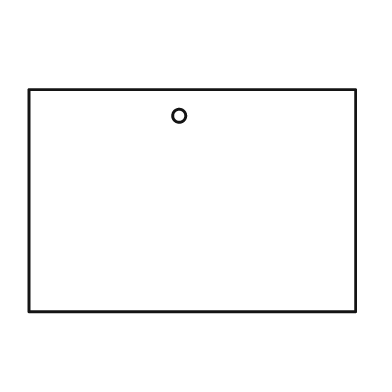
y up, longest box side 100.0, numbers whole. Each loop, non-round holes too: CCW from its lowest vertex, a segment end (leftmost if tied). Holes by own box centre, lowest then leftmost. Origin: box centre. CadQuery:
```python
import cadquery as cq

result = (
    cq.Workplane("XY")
    .moveTo(-50.0, -34.0)
    .lineTo(50.0, -34.0)
    .lineTo(50.0, 34.0)
    .lineTo(-50.0, 34.0)
    .close()
    .moveTo(-4.0, 26.0)
    .circle(2.0)
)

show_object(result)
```